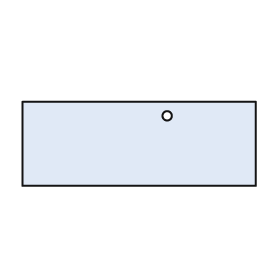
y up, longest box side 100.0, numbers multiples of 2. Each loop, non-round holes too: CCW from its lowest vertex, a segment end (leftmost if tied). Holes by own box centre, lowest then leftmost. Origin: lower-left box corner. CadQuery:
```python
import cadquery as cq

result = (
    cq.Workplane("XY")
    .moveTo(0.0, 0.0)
    .lineTo(100.0, 0.0)
    .lineTo(100.0, 36.0)
    .lineTo(0.0, 36.0)
    .close()
    .moveTo(62.0, 30.0)
    .circle(2.0)
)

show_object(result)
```